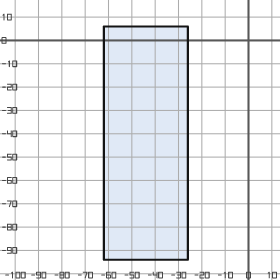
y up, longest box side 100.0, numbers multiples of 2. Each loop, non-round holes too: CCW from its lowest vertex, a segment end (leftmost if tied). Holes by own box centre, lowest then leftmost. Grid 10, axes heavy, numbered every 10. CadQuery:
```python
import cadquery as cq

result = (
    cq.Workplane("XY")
    .moveTo(-62.0, -94.0)
    .lineTo(-26.0, -94.0)
    .lineTo(-26.0, 6.0)
    .lineTo(-62.0, 6.0)
    .close()
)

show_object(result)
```